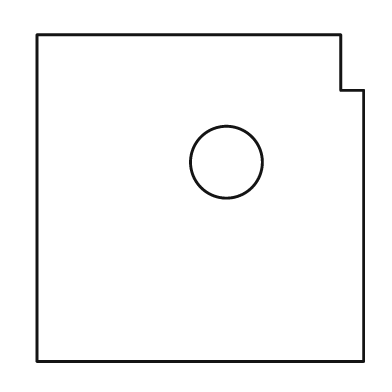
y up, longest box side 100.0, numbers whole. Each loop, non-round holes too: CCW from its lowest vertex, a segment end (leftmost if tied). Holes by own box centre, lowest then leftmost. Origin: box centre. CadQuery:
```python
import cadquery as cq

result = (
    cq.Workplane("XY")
    .moveTo(-50.0, -50.0)
    .lineTo(50.0, -50.0)
    .lineTo(50.0, 33.0)
    .lineTo(43.0, 33.0)
    .lineTo(43.0, 50.0)
    .lineTo(-50.0, 50.0)
    .close()
    .moveTo(8.0, 11.0)
    .circle(11.0)
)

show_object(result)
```